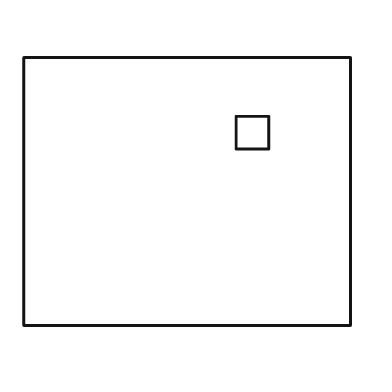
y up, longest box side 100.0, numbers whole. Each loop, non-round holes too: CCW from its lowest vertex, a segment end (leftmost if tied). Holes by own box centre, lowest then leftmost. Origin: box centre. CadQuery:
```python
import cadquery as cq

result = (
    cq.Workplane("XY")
    .moveTo(-50.0, -41.0)
    .lineTo(50.0, -41.0)
    .lineTo(50.0, 41.0)
    .lineTo(-50.0, 41.0)
    .close()
    .moveTo(15.0, 13.0)
    .lineTo(25.0, 13.0)
    .lineTo(25.0, 23.0)
    .lineTo(15.0, 23.0)
    .close()
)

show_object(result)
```